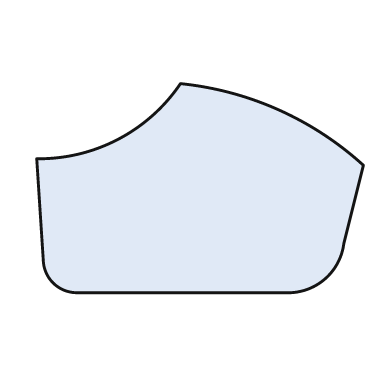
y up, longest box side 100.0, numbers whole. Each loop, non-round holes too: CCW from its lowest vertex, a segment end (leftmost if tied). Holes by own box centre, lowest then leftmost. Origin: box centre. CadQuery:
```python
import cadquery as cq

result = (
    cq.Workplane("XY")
    .moveTo(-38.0, -32.0)
    .lineTo(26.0, -32.0)
    .threePointArc((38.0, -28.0), (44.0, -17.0))
    .lineTo(50.0, 7.0)
    .threePointArc((24.0, 24.0), (-6.0, 32.0))
    .threePointArc((-25.0, 15.0), (-50.0, 9.0))
    .lineTo(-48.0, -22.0)
    .threePointArc((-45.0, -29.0), (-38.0, -32.0))
    .close()
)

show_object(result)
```